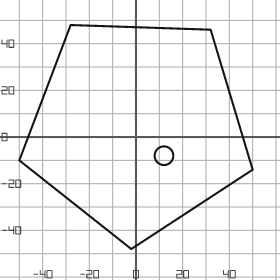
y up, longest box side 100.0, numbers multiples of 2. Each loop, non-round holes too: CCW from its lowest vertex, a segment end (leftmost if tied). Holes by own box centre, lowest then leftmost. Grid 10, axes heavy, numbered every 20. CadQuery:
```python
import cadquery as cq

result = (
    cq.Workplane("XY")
    .moveTo(-2.0, -48.0)
    .lineTo(50.0, -14.0)
    .lineTo(32.0, 46.0)
    .lineTo(-28.0, 48.0)
    .lineTo(-50.0, -10.0)
    .close()
    .moveTo(12.0, -8.0)
    .circle(4.0)
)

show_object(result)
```